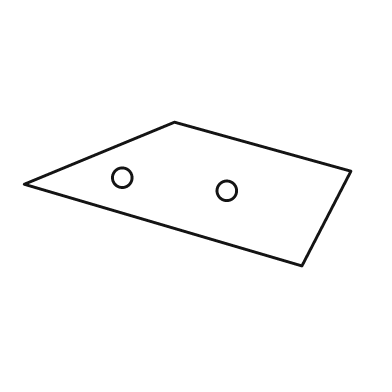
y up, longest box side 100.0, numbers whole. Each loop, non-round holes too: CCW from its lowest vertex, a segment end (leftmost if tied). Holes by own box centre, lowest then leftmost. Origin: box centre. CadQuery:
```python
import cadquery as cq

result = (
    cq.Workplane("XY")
    .moveTo(35.0, -22.0)
    .lineTo(50.0, 7.0)
    .lineTo(-4.0, 22.0)
    .lineTo(-50.0, 3.0)
    .close()
    .moveTo(12.0, 1.0)
    .circle(3.0)
    .moveTo(-20.0, 5.0)
    .circle(3.0)
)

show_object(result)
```